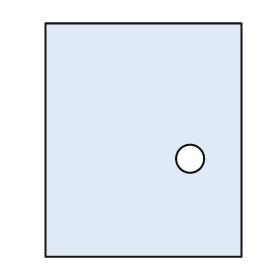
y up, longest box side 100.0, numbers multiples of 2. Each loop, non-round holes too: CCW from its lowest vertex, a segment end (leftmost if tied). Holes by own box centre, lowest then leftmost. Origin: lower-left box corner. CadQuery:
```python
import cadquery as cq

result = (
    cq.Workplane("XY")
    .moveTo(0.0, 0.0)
    .lineTo(84.0, 0.0)
    .lineTo(84.0, 100.0)
    .lineTo(0.0, 100.0)
    .close()
    .moveTo(62.0, 42.0)
    .circle(6.0)
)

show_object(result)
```